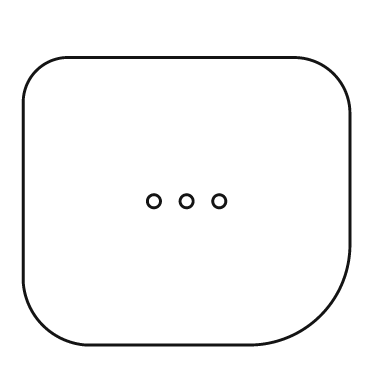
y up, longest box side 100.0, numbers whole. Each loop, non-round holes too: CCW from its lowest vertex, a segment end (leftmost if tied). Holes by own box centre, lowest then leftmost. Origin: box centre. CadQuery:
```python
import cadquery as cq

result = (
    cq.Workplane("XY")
    .moveTo(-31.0, -44.0)
    .lineTo(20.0, -44.0)
    .threePointArc((41.0, -35.0), (50.0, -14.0))
    .lineTo(50.0, 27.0)
    .threePointArc((45.0, 39.0), (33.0, 44.0))
    .lineTo(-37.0, 44.0)
    .threePointArc((-46.0, 40.0), (-50.0, 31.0))
    .lineTo(-50.0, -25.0)
    .threePointArc((-44.0, -38.0), (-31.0, -44.0))
    .close()
    .moveTo(-10.0, 0.0)
    .circle(2.0)
    .moveTo(0.0, 0.0)
    .circle(2.0)
    .moveTo(10.0, 0.0)
    .circle(2.0)
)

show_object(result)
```